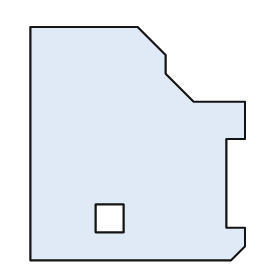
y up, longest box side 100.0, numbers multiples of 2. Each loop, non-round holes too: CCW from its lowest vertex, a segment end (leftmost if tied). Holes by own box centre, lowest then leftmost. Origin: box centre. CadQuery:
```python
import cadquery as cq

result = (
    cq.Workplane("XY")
    .moveTo(-46.0, -50.0)
    .lineTo(40.0, -50.0)
    .lineTo(46.0, -44.0)
    .lineTo(46.0, -36.0)
    .lineTo(38.0, -36.0)
    .lineTo(38.0, 2.0)
    .lineTo(46.0, 2.0)
    .lineTo(46.0, 18.0)
    .lineTo(24.0, 18.0)
    .lineTo(12.0, 30.0)
    .lineTo(12.0, 38.0)
    .lineTo(0.0, 50.0)
    .lineTo(-46.0, 50.0)
    .close()
    .moveTo(-18.0, -38.0)
    .lineTo(-6.0, -38.0)
    .lineTo(-6.0, -26.0)
    .lineTo(-18.0, -26.0)
    .close()
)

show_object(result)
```